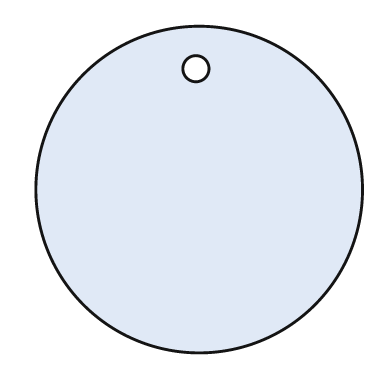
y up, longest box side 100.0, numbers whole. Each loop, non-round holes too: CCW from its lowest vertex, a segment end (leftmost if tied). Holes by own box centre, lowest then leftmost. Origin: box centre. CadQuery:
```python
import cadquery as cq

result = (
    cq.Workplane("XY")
    .moveTo(0.0, 0.0)
    .circle(50.0)
    .moveTo(-1.0, 37.0)
    .circle(4.0)
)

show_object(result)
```